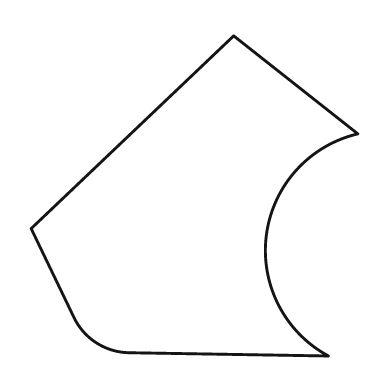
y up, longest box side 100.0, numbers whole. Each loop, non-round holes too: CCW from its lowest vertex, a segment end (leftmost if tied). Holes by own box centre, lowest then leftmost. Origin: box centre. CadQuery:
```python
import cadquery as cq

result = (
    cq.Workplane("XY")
    .moveTo(41.0, -49.0)
    .threePointArc((22.0, -12.0), (50.0, 19.0))
    .lineTo(12.0, 49.0)
    .lineTo(-50.0, -10.0)
    .lineTo(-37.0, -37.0)
    .threePointArc((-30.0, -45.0), (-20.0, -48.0))
    .close()
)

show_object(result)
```